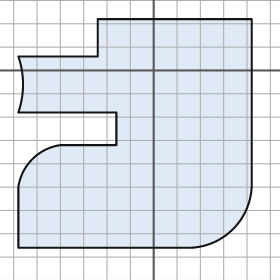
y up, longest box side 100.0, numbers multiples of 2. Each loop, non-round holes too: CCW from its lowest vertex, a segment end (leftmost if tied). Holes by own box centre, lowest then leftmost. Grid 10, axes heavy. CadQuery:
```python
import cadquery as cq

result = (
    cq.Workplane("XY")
    .moveTo(-58.0, -76.0)
    .lineTo(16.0, -76.0)
    .threePointArc((34.0, -68.0), (42.0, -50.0))
    .lineTo(42.0, 22.0)
    .lineTo(-24.0, 22.0)
    .lineTo(-24.0, 6.0)
    .lineTo(-58.0, 6.0)
    .threePointArc((-56.0, -6.0), (-58.0, -18.0))
    .lineTo(-16.0, -18.0)
    .lineTo(-16.0, -32.0)
    .lineTo(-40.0, -32.0)
    .threePointArc((-52.0, -38.0), (-58.0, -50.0))
    .close()
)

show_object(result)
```